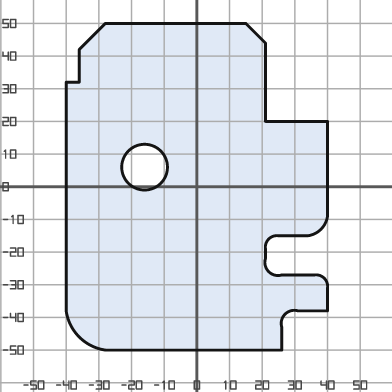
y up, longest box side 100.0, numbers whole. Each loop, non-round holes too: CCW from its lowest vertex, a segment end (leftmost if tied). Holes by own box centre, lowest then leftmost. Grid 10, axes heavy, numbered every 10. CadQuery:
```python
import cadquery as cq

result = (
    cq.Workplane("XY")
    .moveTo(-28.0, -50.0)
    .lineTo(26.0, -50.0)
    .lineTo(26.0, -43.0)
    .threePointArc((27.0, -39.0), (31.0, -38.0))
    .lineTo(40.0, -38.0)
    .lineTo(40.0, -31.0)
    .threePointArc((39.0, -28.0), (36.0, -27.0))
    .lineTo(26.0, -27.0)
    .threePointArc((22.0, -26.0), (21.0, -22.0))
    .lineTo(21.0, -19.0)
    .threePointArc((22.0, -16.0), (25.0, -15.0))
    .lineTo(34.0, -15.0)
    .threePointArc((38.0, -13.0), (40.0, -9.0))
    .lineTo(40.0, 20.0)
    .lineTo(21.0, 20.0)
    .lineTo(21.0, 44.0)
    .lineTo(15.0, 50.0)
    .lineTo(-28.0, 50.0)
    .lineTo(-36.0, 42.0)
    .lineTo(-36.0, 32.0)
    .lineTo(-40.0, 32.0)
    .lineTo(-40.0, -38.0)
    .threePointArc((-36.0, -46.0), (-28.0, -50.0))
    .close()
    .moveTo(-16.0, 6.0)
    .circle(7.0)
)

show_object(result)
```